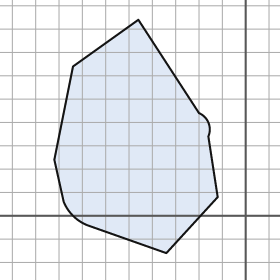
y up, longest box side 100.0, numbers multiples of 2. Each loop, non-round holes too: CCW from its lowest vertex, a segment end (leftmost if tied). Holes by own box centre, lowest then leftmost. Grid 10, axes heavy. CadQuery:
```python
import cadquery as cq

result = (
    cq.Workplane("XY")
    .moveTo(-34.0, -16.0)
    .lineTo(-12.0, 8.0)
    .lineTo(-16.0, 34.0)
    .threePointArc((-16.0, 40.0), (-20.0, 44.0))
    .lineTo(-46.0, 84.0)
    .lineTo(-74.0, 64.0)
    .lineTo(-82.0, 24.0)
    .lineTo(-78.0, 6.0)
    .threePointArc((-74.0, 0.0), (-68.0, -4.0))
    .close()
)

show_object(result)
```